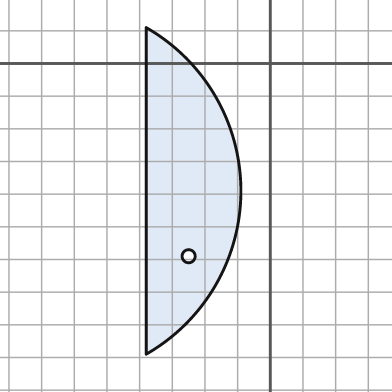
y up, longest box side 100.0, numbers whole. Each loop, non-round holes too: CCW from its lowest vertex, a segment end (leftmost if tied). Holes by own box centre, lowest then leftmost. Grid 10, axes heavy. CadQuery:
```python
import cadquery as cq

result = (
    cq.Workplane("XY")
    .moveTo(-38.0, -89.0)
    .threePointArc((-9.0, -39.0), (-38.0, 11.0))
    .close()
    .moveTo(-25.0, -59.0)
    .circle(2.0)
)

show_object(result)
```